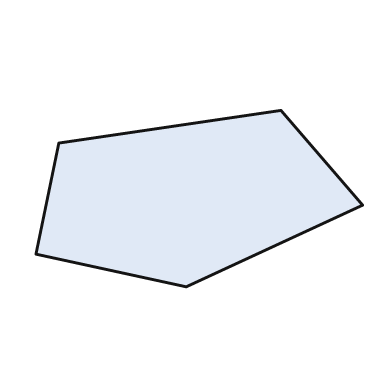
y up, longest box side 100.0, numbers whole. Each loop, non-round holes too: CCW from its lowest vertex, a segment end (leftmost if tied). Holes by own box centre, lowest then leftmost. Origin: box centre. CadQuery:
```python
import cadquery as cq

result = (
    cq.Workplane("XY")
    .moveTo(-4.0, -27.0)
    .lineTo(50.0, -2.0)
    .lineTo(25.0, 27.0)
    .lineTo(-43.0, 17.0)
    .lineTo(-50.0, -17.0)
    .close()
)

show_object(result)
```